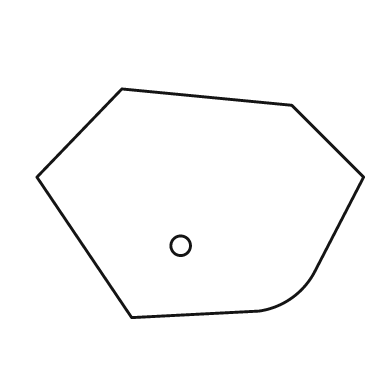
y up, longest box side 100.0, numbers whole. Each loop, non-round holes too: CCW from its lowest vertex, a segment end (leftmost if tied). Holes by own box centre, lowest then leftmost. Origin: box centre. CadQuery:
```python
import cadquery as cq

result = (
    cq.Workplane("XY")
    .moveTo(-21.0, -35.0)
    .lineTo(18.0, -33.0)
    .threePointArc((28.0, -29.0), (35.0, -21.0))
    .lineTo(50.0, 8.0)
    .lineTo(28.0, 30.0)
    .lineTo(-24.0, 35.0)
    .lineTo(-50.0, 8.0)
    .close()
    .moveTo(-6.0, -13.0)
    .circle(3.0)
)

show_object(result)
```